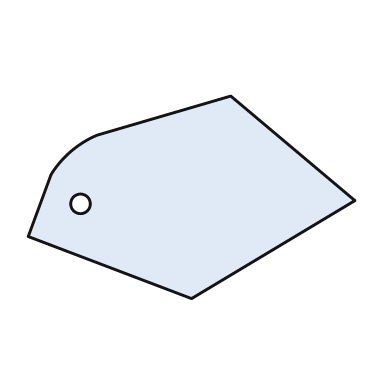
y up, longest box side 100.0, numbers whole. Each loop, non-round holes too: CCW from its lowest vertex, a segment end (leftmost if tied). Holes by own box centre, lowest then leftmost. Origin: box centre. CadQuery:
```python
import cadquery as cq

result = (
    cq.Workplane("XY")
    .moveTo(0.0, -31.0)
    .lineTo(50.0, -1.0)
    .lineTo(12.0, 31.0)
    .lineTo(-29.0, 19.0)
    .threePointArc((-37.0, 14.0), (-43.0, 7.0))
    .lineTo(-50.0, -12.0)
    .close()
    .moveTo(-34.0, -2.0)
    .circle(3.0)
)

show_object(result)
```